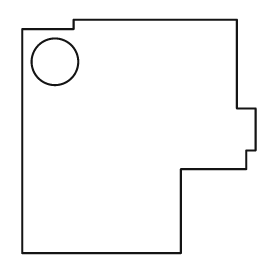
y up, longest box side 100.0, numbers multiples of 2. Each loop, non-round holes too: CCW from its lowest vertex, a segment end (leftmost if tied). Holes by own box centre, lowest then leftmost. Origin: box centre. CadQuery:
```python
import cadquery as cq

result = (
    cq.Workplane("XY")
    .moveTo(-50.0, -50.0)
    .lineTo(18.0, -50.0)
    .lineTo(18.0, -14.0)
    .lineTo(46.0, -14.0)
    .lineTo(46.0, -6.0)
    .lineTo(50.0, -6.0)
    .lineTo(50.0, 12.0)
    .lineTo(42.0, 12.0)
    .lineTo(42.0, 50.0)
    .lineTo(-28.0, 50.0)
    .lineTo(-28.0, 46.0)
    .lineTo(-50.0, 46.0)
    .close()
    .moveTo(-36.0, 32.0)
    .circle(10.0)
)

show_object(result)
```